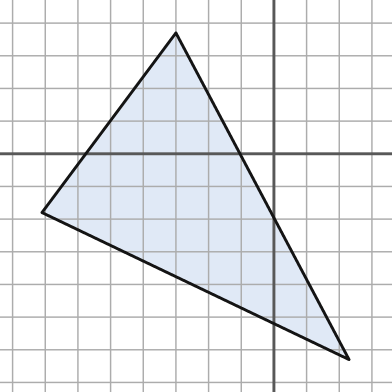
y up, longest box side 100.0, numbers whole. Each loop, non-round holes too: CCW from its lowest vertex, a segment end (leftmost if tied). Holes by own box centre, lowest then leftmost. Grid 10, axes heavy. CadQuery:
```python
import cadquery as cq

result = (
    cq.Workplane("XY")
    .moveTo(23.0, -63.0)
    .lineTo(-30.0, 37.0)
    .lineTo(-71.0, -18.0)
    .close()
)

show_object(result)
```